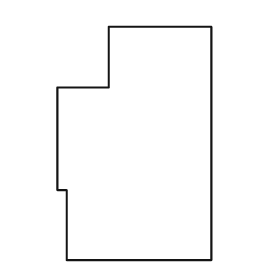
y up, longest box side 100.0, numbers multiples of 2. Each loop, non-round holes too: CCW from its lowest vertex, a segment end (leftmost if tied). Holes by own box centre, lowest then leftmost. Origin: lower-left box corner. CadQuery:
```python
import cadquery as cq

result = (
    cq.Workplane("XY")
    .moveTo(4.0, 0.0)
    .lineTo(66.0, 0.0)
    .lineTo(66.0, 100.0)
    .lineTo(22.0, 100.0)
    .lineTo(22.0, 74.0)
    .lineTo(0.0, 74.0)
    .lineTo(0.0, 30.0)
    .lineTo(4.0, 30.0)
    .close()
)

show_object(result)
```